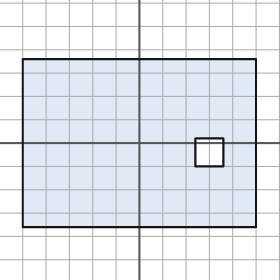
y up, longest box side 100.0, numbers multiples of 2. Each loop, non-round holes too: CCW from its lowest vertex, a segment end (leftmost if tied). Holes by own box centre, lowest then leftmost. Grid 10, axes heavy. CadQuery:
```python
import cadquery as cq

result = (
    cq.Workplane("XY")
    .moveTo(-50.0, -36.0)
    .lineTo(50.0, -36.0)
    .lineTo(50.0, 36.0)
    .lineTo(-50.0, 36.0)
    .close()
    .moveTo(24.0, -10.0)
    .lineTo(36.0, -10.0)
    .lineTo(36.0, 2.0)
    .lineTo(24.0, 2.0)
    .close()
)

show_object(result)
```